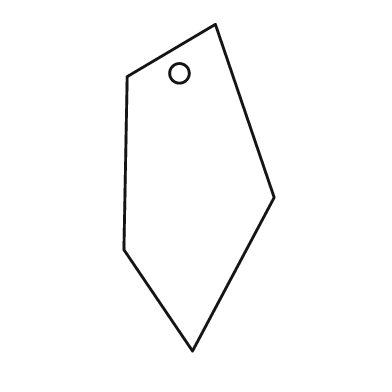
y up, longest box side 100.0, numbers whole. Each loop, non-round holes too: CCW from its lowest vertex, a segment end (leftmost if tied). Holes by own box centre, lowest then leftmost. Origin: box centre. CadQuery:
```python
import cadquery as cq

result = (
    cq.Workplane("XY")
    .moveTo(-2.0, -50.0)
    .lineTo(23.0, -3.0)
    .lineTo(5.0, 50.0)
    .lineTo(-22.0, 34.0)
    .lineTo(-23.0, -19.0)
    .close()
    .moveTo(-6.0, 35.0)
    .circle(3.0)
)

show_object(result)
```